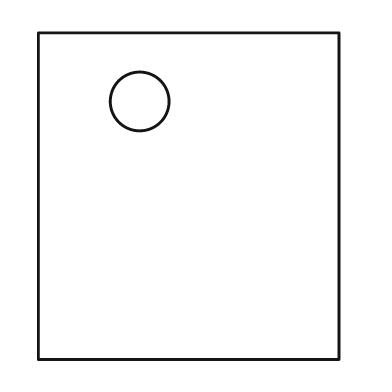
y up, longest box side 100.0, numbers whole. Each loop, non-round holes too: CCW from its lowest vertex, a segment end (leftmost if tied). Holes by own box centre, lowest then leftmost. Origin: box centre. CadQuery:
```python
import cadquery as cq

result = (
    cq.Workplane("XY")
    .moveTo(-46.0, -50.0)
    .lineTo(46.0, -50.0)
    .lineTo(46.0, 50.0)
    .lineTo(-46.0, 50.0)
    .close()
    .moveTo(-15.0, 29.0)
    .circle(9.0)
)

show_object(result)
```